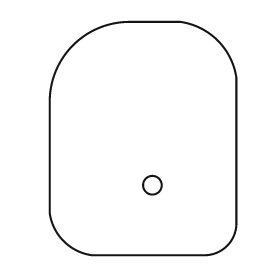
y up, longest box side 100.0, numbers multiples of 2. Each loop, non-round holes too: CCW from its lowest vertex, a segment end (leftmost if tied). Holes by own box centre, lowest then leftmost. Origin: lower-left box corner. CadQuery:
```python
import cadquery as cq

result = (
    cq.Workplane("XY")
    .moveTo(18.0, 0.0)
    .lineTo(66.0, 0.0)
    .threePointArc((76.0, 4.0), (80.0, 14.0))
    .lineTo(80.0, 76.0)
    .threePointArc((72.0, 92.0), (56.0, 100.0))
    .lineTo(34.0, 100.0)
    .threePointArc((10.0, 90.0), (0.0, 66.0))
    .lineTo(0.0, 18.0)
    .threePointArc((6.0, 6.0), (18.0, 0.0))
    .close()
    .moveTo(44.0, 30.0)
    .circle(4.0)
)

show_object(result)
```